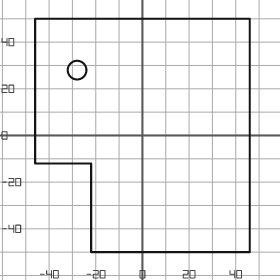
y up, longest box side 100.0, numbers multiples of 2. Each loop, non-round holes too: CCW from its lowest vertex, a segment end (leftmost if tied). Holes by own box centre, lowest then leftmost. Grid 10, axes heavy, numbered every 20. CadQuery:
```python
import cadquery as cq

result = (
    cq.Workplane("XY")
    .moveTo(-22.0, -50.0)
    .lineTo(46.0, -50.0)
    .lineTo(46.0, 50.0)
    .lineTo(-46.0, 50.0)
    .lineTo(-46.0, -12.0)
    .lineTo(-22.0, -12.0)
    .close()
    .moveTo(-28.0, 28.0)
    .circle(4.0)
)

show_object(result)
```